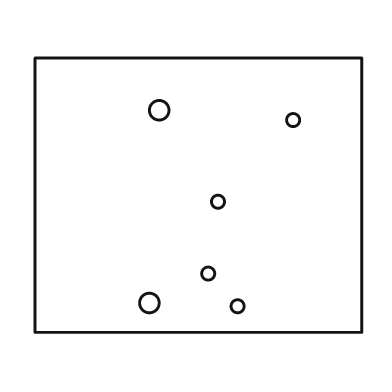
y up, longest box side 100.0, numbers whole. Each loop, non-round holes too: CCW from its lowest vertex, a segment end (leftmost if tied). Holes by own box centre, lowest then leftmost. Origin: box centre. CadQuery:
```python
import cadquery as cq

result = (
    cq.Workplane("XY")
    .moveTo(-50.0, -42.0)
    .lineTo(50.0, -42.0)
    .lineTo(50.0, 42.0)
    .lineTo(-50.0, 42.0)
    .close()
    .moveTo(12.0, -34.0)
    .circle(2.0)
    .moveTo(-15.0, -33.0)
    .circle(3.0)
    .moveTo(3.0, -24.0)
    .circle(2.0)
    .moveTo(6.0, -2.0)
    .circle(2.0)
    .moveTo(29.0, 23.0)
    .circle(2.0)
    .moveTo(-12.0, 26.0)
    .circle(3.0)
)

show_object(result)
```